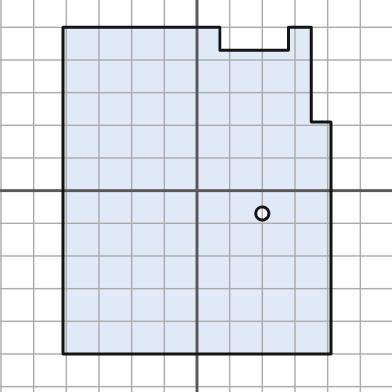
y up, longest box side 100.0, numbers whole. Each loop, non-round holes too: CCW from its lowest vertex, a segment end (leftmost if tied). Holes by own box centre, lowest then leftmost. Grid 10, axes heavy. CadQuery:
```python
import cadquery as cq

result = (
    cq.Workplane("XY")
    .moveTo(-41.0, -50.0)
    .lineTo(41.0, -50.0)
    .lineTo(41.0, 21.0)
    .lineTo(35.0, 21.0)
    .lineTo(35.0, 50.0)
    .lineTo(28.0, 50.0)
    .lineTo(28.0, 43.0)
    .lineTo(7.0, 43.0)
    .lineTo(7.0, 50.0)
    .lineTo(-41.0, 50.0)
    .close()
    .moveTo(20.0, -7.0)
    .circle(2.0)
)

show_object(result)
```